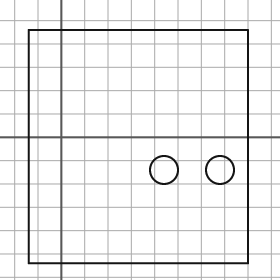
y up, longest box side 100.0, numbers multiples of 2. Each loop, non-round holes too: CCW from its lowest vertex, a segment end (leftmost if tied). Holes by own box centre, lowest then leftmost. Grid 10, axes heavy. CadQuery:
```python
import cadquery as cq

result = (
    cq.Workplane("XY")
    .moveTo(-14.0, -54.0)
    .lineTo(80.0, -54.0)
    .lineTo(80.0, 46.0)
    .lineTo(-14.0, 46.0)
    .close()
    .moveTo(44.0, -14.0)
    .circle(6.0)
    .moveTo(68.0, -14.0)
    .circle(6.0)
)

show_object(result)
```